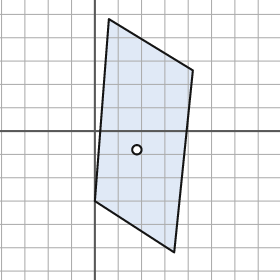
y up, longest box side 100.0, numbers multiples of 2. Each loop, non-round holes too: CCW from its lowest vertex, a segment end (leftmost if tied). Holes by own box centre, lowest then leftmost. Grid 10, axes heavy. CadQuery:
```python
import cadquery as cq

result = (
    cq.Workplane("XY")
    .moveTo(34.0, -52.0)
    .lineTo(42.0, 26.0)
    .lineTo(6.0, 48.0)
    .lineTo(0.0, -30.0)
    .close()
    .moveTo(18.0, -8.0)
    .circle(2.0)
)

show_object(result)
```